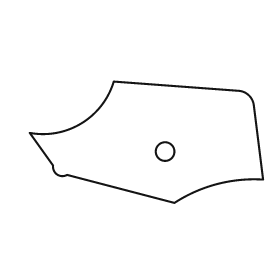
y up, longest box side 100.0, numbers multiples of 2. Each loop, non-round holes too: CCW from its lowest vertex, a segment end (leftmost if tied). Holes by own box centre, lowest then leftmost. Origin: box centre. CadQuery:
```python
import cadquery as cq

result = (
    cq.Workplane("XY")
    .moveTo(12.0, -26.0)
    .threePointArc((30.0, -18.0), (50.0, -16.0))
    .lineTo(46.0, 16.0)
    .threePointArc((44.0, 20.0), (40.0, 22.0))
    .lineTo(-14.0, 26.0)
    .threePointArc((-28.0, 8.0), (-50.0, 4.0))
    .lineTo(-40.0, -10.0)
    .threePointArc((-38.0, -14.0), (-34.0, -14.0))
    .close()
    .moveTo(8.0, -4.0)
    .circle(4.0)
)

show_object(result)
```